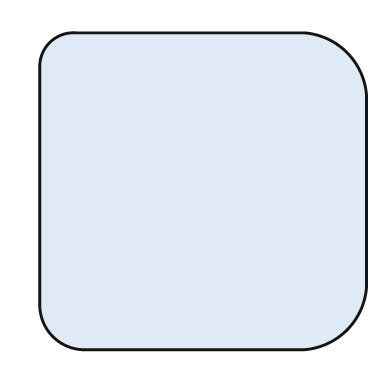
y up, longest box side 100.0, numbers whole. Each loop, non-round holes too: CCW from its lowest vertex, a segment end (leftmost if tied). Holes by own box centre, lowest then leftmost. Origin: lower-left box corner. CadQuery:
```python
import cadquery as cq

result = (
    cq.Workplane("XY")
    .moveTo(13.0, 0.0)
    .lineTo(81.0, 0.0)
    .threePointArc((94.0, 6.0), (100.0, 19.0))
    .lineTo(100.0, 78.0)
    .threePointArc((94.0, 91.0), (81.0, 97.0))
    .lineTo(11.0, 97.0)
    .threePointArc((3.0, 94.0), (0.0, 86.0))
    .lineTo(0.0, 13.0)
    .threePointArc((4.0, 4.0), (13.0, 0.0))
    .close()
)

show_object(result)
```